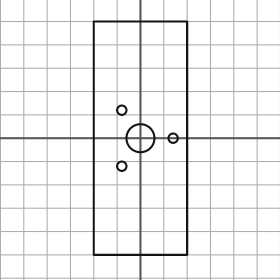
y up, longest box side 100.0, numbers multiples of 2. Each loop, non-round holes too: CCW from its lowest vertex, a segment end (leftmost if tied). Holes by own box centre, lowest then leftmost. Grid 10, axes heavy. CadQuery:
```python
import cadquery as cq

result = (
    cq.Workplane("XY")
    .moveTo(-20.0, -50.0)
    .lineTo(20.0, -50.0)
    .lineTo(20.0, 50.0)
    .lineTo(-20.0, 50.0)
    .close()
    .moveTo(-8.0, -12.0)
    .circle(2.0)
    .moveTo(0.0, 0.0)
    .circle(6.0)
    .moveTo(14.0, 0.0)
    .circle(2.0)
    .moveTo(-8.0, 12.0)
    .circle(2.0)
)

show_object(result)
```